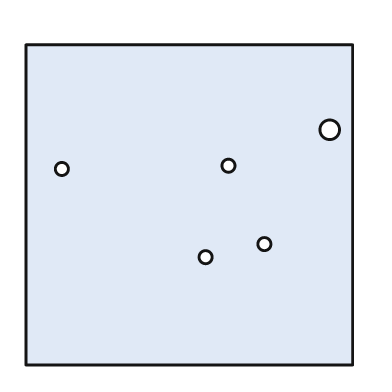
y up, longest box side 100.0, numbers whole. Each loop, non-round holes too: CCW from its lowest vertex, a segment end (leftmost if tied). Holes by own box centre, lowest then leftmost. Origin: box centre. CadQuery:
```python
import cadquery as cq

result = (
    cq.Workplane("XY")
    .moveTo(-50.0, -49.0)
    .lineTo(50.0, -49.0)
    .lineTo(50.0, 49.0)
    .lineTo(-50.0, 49.0)
    .close()
    .moveTo(5.0, -16.0)
    .circle(2.0)
    .moveTo(23.0, -12.0)
    .circle(2.0)
    .moveTo(-39.0, 11.0)
    .circle(2.0)
    .moveTo(12.0, 12.0)
    .circle(2.0)
    .moveTo(43.0, 23.0)
    .circle(3.0)
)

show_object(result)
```